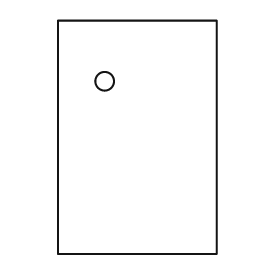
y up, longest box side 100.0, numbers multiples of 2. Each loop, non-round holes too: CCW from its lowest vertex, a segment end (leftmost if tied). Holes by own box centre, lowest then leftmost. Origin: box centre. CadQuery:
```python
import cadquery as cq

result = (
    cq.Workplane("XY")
    .moveTo(-34.0, -50.0)
    .lineTo(34.0, -50.0)
    .lineTo(34.0, 50.0)
    .lineTo(-34.0, 50.0)
    .close()
    .moveTo(-14.0, 24.0)
    .circle(4.0)
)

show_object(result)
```